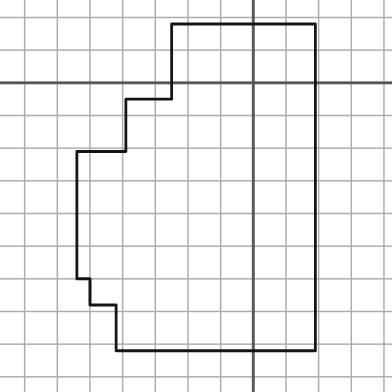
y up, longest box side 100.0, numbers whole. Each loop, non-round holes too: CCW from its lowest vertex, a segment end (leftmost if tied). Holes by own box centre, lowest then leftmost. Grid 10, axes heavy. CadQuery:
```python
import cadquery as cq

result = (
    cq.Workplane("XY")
    .moveTo(-42.0, -82.0)
    .lineTo(19.0, -82.0)
    .lineTo(19.0, 18.0)
    .lineTo(-25.0, 18.0)
    .lineTo(-25.0, -5.0)
    .lineTo(-39.0, -5.0)
    .lineTo(-39.0, -21.0)
    .lineTo(-54.0, -21.0)
    .lineTo(-54.0, -60.0)
    .lineTo(-50.0, -60.0)
    .lineTo(-50.0, -68.0)
    .lineTo(-42.0, -68.0)
    .close()
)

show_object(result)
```